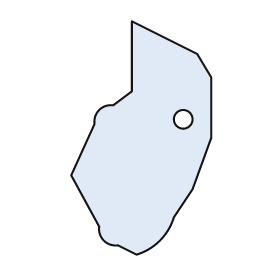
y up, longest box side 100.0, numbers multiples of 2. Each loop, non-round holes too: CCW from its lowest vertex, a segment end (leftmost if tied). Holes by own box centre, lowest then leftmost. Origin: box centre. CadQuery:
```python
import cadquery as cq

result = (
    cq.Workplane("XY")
    .moveTo(-2.0, -50.0)
    .threePointArc((8.0, -44.0), (14.0, -34.0))
    .lineTo(22.0, -22.0)
    .lineTo(30.0, 0.0)
    .lineTo(30.0, 26.0)
    .lineTo(24.0, 36.0)
    .lineTo(-4.0, 50.0)
    .lineTo(-4.0, 20.0)
    .lineTo(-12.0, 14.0)
    .threePointArc((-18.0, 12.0), (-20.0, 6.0))
    .lineTo(-30.0, -16.0)
    .lineTo(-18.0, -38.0)
    .threePointArc((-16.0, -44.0), (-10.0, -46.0))
    .close()
    .moveTo(18.0, 8.0)
    .circle(4.0)
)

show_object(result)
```